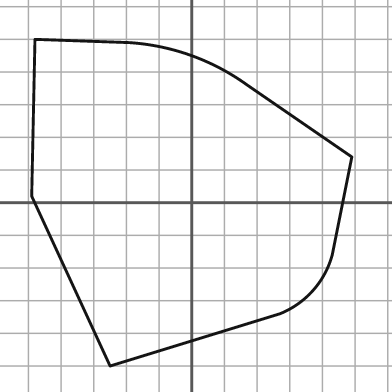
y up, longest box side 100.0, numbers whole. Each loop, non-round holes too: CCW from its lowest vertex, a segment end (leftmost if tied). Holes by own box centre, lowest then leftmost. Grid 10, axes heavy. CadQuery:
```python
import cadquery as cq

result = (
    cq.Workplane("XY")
    .moveTo(-25.0, -50.0)
    .lineTo(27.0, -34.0)
    .threePointArc((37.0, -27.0), (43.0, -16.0))
    .lineTo(49.0, 14.0)
    .lineTo(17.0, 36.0)
    .threePointArc((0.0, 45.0), (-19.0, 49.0))
    .lineTo(-48.0, 50.0)
    .lineTo(-49.0, 2.0)
    .close()
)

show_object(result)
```